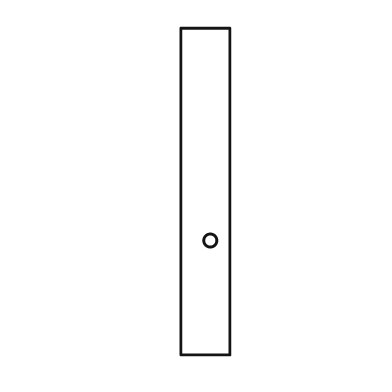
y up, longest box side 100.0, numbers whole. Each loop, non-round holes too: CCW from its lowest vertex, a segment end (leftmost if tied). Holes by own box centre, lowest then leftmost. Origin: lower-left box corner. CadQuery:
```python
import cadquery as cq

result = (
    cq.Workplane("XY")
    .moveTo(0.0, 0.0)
    .lineTo(15.0, 0.0)
    .lineTo(15.0, 100.0)
    .lineTo(0.0, 100.0)
    .close()
    .moveTo(9.0, 35.0)
    .circle(2.0)
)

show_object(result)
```